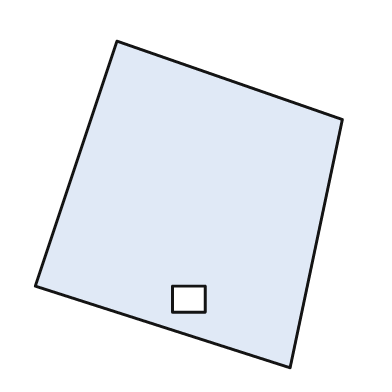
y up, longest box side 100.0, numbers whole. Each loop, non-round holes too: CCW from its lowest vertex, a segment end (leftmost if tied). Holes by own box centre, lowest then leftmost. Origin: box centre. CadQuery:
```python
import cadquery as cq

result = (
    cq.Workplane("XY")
    .moveTo(31.0, -50.0)
    .lineTo(47.0, 26.0)
    .lineTo(-22.0, 50.0)
    .lineTo(-47.0, -25.0)
    .close()
    .moveTo(-5.0, -33.0)
    .lineTo(5.0, -33.0)
    .lineTo(5.0, -25.0)
    .lineTo(-5.0, -25.0)
    .close()
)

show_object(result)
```